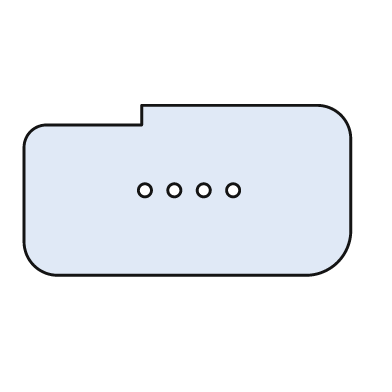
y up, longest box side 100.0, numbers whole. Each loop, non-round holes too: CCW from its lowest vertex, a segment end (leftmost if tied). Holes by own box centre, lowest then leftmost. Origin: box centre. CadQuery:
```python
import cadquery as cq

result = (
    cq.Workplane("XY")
    .moveTo(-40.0, -26.0)
    .lineTo(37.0, -26.0)
    .threePointArc((46.0, -22.0), (50.0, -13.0))
    .lineTo(50.0, 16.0)
    .threePointArc((47.0, 23.0), (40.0, 26.0))
    .lineTo(-14.0, 26.0)
    .lineTo(-14.0, 20.0)
    .lineTo(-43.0, 20.0)
    .threePointArc((-48.0, 18.0), (-50.0, 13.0))
    .lineTo(-50.0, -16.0)
    .threePointArc((-47.0, -23.0), (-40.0, -26.0))
    .close()
    .moveTo(-13.0, 0.0)
    .circle(2.0)
    .moveTo(-4.0, 0.0)
    .circle(2.0)
    .moveTo(5.0, 0.0)
    .circle(2.0)
    .moveTo(14.0, 0.0)
    .circle(2.0)
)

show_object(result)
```